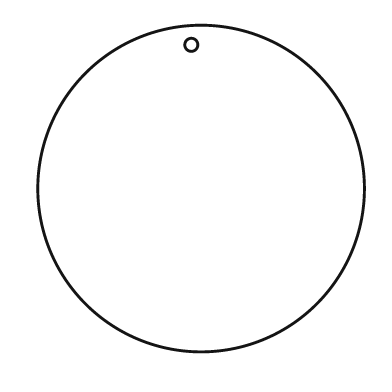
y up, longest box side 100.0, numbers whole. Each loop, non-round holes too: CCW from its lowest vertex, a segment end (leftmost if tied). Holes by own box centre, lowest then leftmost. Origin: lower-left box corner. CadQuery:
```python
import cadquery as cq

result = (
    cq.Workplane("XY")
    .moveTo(50.0, 50.0)
    .circle(50.0)
    .moveTo(47.0, 94.0)
    .circle(2.0)
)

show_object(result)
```